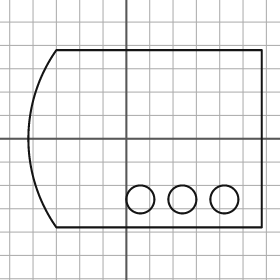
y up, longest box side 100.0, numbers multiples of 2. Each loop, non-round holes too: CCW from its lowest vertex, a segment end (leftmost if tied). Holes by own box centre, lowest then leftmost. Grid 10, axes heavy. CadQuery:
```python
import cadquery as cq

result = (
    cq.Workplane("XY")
    .moveTo(-30.0, -38.0)
    .lineTo(58.0, -38.0)
    .lineTo(58.0, 38.0)
    .lineTo(-30.0, 38.0)
    .threePointArc((-42.0, 0.0), (-30.0, -38.0))
    .close()
    .moveTo(6.0, -26.0)
    .circle(6.0)
    .moveTo(24.0, -26.0)
    .circle(6.0)
    .moveTo(42.0, -26.0)
    .circle(6.0)
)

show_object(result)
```